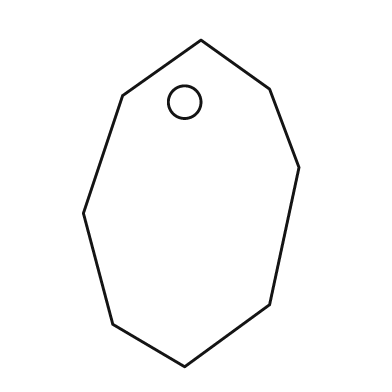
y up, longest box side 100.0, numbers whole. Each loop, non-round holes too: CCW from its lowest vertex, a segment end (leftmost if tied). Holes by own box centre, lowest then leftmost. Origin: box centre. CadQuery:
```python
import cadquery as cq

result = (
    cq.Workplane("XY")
    .moveTo(-2.0, -50.0)
    .lineTo(24.0, -31.0)
    .lineTo(33.0, 11.0)
    .lineTo(24.0, 35.0)
    .lineTo(3.0, 50.0)
    .lineTo(-21.0, 33.0)
    .lineTo(-33.0, -3.0)
    .lineTo(-24.0, -37.0)
    .close()
    .moveTo(-2.0, 31.0)
    .circle(5.0)
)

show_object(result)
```